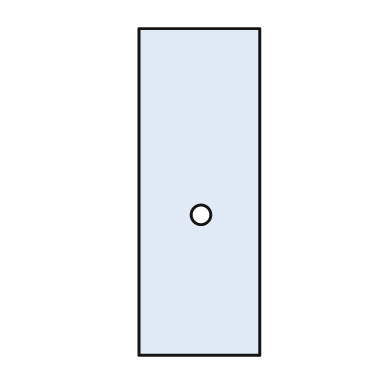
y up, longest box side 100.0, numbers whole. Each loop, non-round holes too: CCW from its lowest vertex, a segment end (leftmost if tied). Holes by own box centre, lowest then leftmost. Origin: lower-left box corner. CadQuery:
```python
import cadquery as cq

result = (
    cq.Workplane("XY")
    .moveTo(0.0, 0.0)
    .lineTo(37.0, 0.0)
    .lineTo(37.0, 100.0)
    .lineTo(0.0, 100.0)
    .close()
    .moveTo(19.0, 43.0)
    .circle(3.0)
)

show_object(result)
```